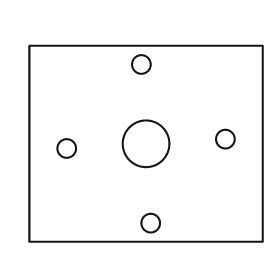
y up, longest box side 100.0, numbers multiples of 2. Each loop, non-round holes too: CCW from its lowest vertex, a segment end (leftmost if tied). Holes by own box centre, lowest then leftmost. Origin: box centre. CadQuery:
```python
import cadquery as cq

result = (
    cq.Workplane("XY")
    .moveTo(-50.0, -42.0)
    .lineTo(50.0, -42.0)
    .lineTo(50.0, 42.0)
    .lineTo(-50.0, 42.0)
    .close()
    .moveTo(2.0, -34.0)
    .circle(4.0)
    .moveTo(-34.0, -2.0)
    .circle(4.0)
    .moveTo(0.0, 0.0)
    .circle(10.0)
    .moveTo(34.0, 2.0)
    .circle(4.0)
    .moveTo(-2.0, 34.0)
    .circle(4.0)
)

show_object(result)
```